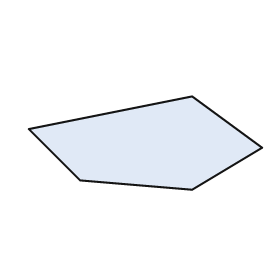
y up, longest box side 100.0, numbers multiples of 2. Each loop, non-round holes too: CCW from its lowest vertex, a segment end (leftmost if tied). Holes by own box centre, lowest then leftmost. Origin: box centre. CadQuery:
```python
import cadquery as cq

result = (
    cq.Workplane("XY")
    .moveTo(20.0, -20.0)
    .lineTo(50.0, -2.0)
    .lineTo(20.0, 20.0)
    .lineTo(-50.0, 6.0)
    .lineTo(-28.0, -16.0)
    .close()
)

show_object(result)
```